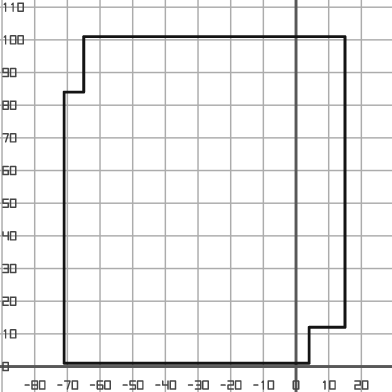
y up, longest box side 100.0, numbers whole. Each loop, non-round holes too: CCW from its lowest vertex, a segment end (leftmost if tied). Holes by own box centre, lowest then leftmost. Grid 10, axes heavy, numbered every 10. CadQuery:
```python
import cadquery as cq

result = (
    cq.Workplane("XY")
    .moveTo(-71.0, 1.0)
    .lineTo(4.0, 1.0)
    .lineTo(4.0, 12.0)
    .lineTo(15.0, 12.0)
    .lineTo(15.0, 101.0)
    .lineTo(-65.0, 101.0)
    .lineTo(-65.0, 84.0)
    .lineTo(-71.0, 84.0)
    .close()
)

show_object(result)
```